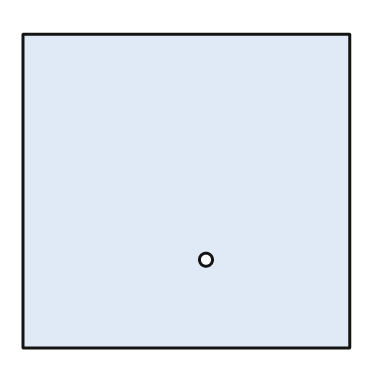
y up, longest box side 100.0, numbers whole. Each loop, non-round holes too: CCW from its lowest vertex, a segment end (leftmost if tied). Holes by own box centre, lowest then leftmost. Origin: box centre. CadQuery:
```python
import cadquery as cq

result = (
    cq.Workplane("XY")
    .moveTo(-50.0, -48.0)
    .lineTo(50.0, -48.0)
    .lineTo(50.0, 48.0)
    .lineTo(-50.0, 48.0)
    .close()
    .moveTo(6.0, -21.0)
    .circle(2.0)
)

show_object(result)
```